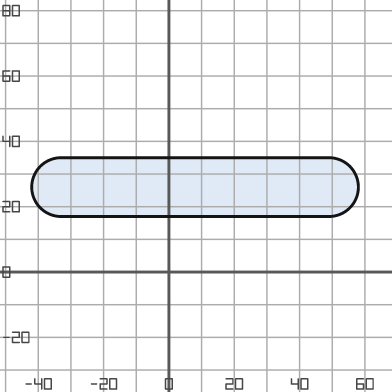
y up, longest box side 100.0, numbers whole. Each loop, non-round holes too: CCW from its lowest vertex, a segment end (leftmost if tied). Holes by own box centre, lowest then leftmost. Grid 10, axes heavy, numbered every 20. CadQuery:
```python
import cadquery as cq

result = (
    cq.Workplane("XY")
    .moveTo(-33.0, 17.0)
    .lineTo(49.0, 17.0)
    .threePointArc((58.0, 26.0), (49.0, 35.0))
    .lineTo(-33.0, 35.0)
    .threePointArc((-42.0, 26.0), (-33.0, 17.0))
    .close()
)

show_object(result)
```